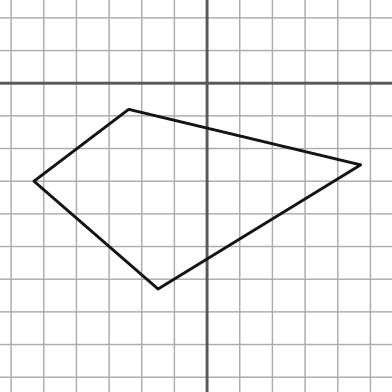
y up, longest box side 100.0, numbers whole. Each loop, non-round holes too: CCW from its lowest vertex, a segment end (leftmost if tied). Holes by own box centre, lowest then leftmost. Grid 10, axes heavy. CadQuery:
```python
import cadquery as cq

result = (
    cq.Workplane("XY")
    .moveTo(-15.0, -63.0)
    .lineTo(47.0, -25.0)
    .lineTo(-24.0, -8.0)
    .lineTo(-53.0, -30.0)
    .close()
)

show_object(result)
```